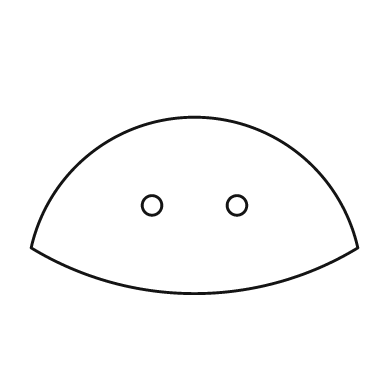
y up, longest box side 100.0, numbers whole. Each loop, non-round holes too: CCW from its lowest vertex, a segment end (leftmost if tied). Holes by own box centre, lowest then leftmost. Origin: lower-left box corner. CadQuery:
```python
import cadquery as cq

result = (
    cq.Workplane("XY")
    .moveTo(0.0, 14.0)
    .threePointArc((50.0, 0.0), (100.0, 14.0))
    .threePointArc((50.0, 54.0), (0.0, 14.0))
    .close()
    .moveTo(37.0, 27.0)
    .circle(3.0)
    .moveTo(63.0, 27.0)
    .circle(3.0)
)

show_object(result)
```